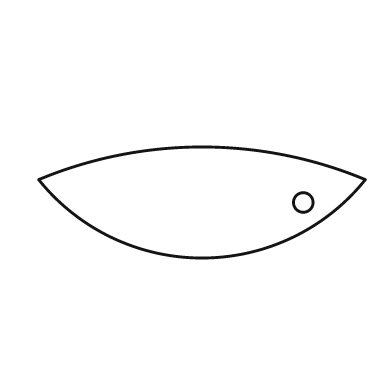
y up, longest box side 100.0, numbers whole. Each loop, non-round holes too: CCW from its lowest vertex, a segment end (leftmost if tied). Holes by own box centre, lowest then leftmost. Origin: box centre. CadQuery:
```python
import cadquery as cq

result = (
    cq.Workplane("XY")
    .moveTo(-50.0, 7.0)
    .threePointArc((0.0, -17.0), (50.0, 7.0))
    .threePointArc((0.0, 17.0), (-50.0, 7.0))
    .close()
    .moveTo(31.0, 0.0)
    .circle(3.0)
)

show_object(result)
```